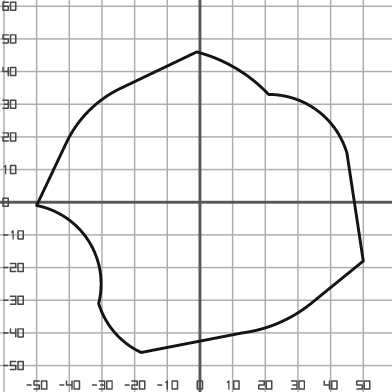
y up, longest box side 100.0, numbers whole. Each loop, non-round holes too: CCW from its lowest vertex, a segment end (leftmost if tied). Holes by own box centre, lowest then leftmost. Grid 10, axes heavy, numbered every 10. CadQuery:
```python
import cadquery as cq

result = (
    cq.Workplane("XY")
    .moveTo(-18.0, -46.0)
    .lineTo(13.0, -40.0)
    .threePointArc((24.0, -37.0), (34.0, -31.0))
    .lineTo(50.0, -18.0)
    .lineTo(45.0, 15.0)
    .threePointArc((36.0, 28.0), (21.0, 33.0))
    .threePointArc((11.0, 41.0), (-1.0, 46.0))
    .lineTo(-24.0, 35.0)
    .threePointArc((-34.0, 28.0), (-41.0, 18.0))
    .lineTo(-50.0, -1.0)
    .threePointArc((-34.0, -12.0), (-31.0, -31.0))
    .threePointArc((-26.0, -40.0), (-18.0, -46.0))
    .close()
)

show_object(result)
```